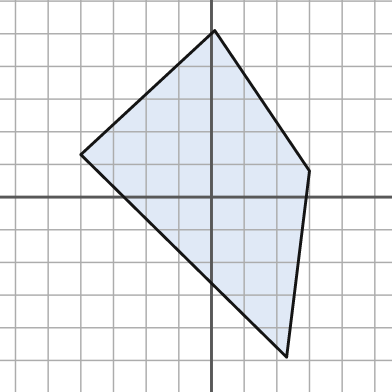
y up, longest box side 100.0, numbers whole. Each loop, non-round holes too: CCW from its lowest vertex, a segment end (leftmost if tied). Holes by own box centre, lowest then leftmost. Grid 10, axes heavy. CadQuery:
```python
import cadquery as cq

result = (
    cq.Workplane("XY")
    .moveTo(23.0, -49.0)
    .lineTo(30.0, 8.0)
    .lineTo(1.0, 51.0)
    .lineTo(-40.0, 13.0)
    .close()
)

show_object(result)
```